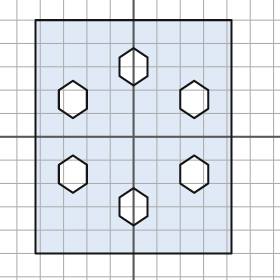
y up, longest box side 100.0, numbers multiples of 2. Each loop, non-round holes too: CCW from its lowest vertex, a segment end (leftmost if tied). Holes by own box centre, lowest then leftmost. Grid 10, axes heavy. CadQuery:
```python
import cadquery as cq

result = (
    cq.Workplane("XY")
    .moveTo(-42.0, -50.0)
    .lineTo(42.0, -50.0)
    .lineTo(42.0, 50.0)
    .lineTo(-42.0, 50.0)
    .close()
    .moveTo(0.0, -38.0)
    .lineTo(6.0, -34.0)
    .lineTo(6.0, -26.0)
    .lineTo(0.0, -22.0)
    .lineTo(-6.0, -26.0)
    .lineTo(-6.0, -34.0)
    .close()
    .moveTo(-26.0, -24.0)
    .lineTo(-20.0, -20.0)
    .lineTo(-20.0, -12.0)
    .lineTo(-26.0, -8.0)
    .lineTo(-32.0, -12.0)
    .lineTo(-32.0, -20.0)
    .close()
    .moveTo(26.0, -24.0)
    .lineTo(32.0, -20.0)
    .lineTo(32.0, -12.0)
    .lineTo(26.0, -8.0)
    .lineTo(20.0, -12.0)
    .lineTo(20.0, -20.0)
    .close()
    .moveTo(-26.0, 8.0)
    .lineTo(-20.0, 12.0)
    .lineTo(-20.0, 20.0)
    .lineTo(-26.0, 24.0)
    .lineTo(-32.0, 20.0)
    .lineTo(-32.0, 12.0)
    .close()
    .moveTo(26.0, 8.0)
    .lineTo(32.0, 12.0)
    .lineTo(32.0, 20.0)
    .lineTo(26.0, 24.0)
    .lineTo(20.0, 20.0)
    .lineTo(20.0, 12.0)
    .close()
    .moveTo(0.0, 22.0)
    .lineTo(6.0, 26.0)
    .lineTo(6.0, 34.0)
    .lineTo(0.0, 38.0)
    .lineTo(-6.0, 34.0)
    .lineTo(-6.0, 26.0)
    .close()
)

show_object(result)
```